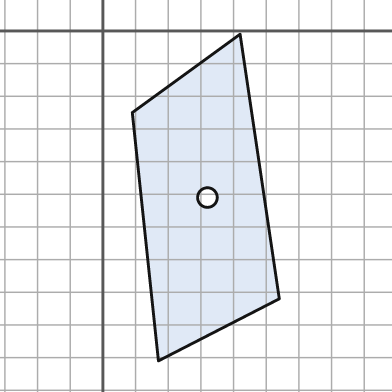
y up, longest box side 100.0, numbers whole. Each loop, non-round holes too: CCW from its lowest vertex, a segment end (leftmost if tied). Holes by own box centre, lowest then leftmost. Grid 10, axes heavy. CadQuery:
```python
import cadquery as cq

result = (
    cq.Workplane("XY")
    .moveTo(17.0, -101.0)
    .lineTo(54.0, -82.0)
    .lineTo(42.0, -1.0)
    .lineTo(9.0, -25.0)
    .close()
    .moveTo(32.0, -51.0)
    .circle(3.0)
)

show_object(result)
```